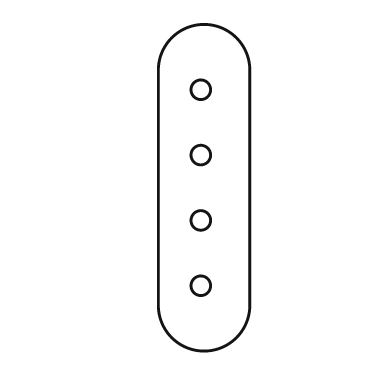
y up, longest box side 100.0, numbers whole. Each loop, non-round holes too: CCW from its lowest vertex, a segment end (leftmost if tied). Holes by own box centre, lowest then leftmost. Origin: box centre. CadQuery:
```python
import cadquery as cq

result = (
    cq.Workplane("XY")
    .moveTo(-14.0, -36.0)
    .threePointArc((0.0, -50.0), (14.0, -36.0))
    .lineTo(14.0, 36.0)
    .threePointArc((0.0, 50.0), (-14.0, 36.0))
    .close()
    .moveTo(-1.0, -30.0)
    .circle(3.0)
    .moveTo(-1.0, -10.0)
    .circle(3.0)
    .moveTo(-1.0, 10.0)
    .circle(3.0)
    .moveTo(-1.0, 30.0)
    .circle(3.0)
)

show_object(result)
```